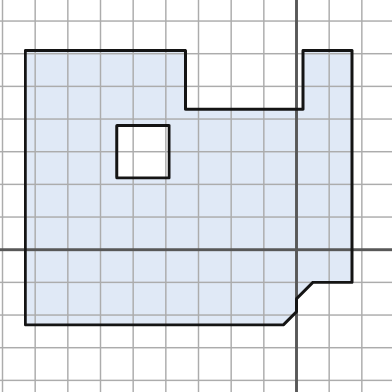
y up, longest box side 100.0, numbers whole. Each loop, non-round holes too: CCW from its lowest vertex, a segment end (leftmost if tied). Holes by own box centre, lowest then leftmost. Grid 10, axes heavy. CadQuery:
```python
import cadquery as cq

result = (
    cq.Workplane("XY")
    .moveTo(-83.0, -23.0)
    .lineTo(-4.0, -23.0)
    .lineTo(0.0, -19.0)
    .lineTo(0.0, -15.0)
    .lineTo(5.0, -10.0)
    .lineTo(17.0, -10.0)
    .lineTo(17.0, 61.0)
    .lineTo(2.0, 61.0)
    .lineTo(2.0, 43.0)
    .lineTo(-34.0, 43.0)
    .lineTo(-34.0, 61.0)
    .lineTo(-83.0, 61.0)
    .close()
    .moveTo(-55.0, 22.0)
    .lineTo(-39.0, 22.0)
    .lineTo(-39.0, 38.0)
    .lineTo(-55.0, 38.0)
    .close()
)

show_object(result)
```